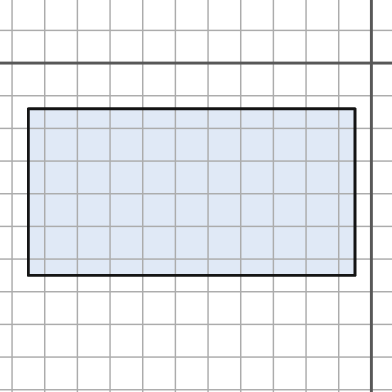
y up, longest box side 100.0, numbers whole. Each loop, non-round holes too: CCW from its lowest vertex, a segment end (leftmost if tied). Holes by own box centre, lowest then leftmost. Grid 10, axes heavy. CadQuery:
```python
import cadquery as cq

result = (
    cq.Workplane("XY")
    .moveTo(-105.0, -65.0)
    .lineTo(-5.0, -65.0)
    .lineTo(-5.0, -14.0)
    .lineTo(-105.0, -14.0)
    .close()
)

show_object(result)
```